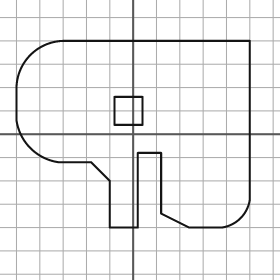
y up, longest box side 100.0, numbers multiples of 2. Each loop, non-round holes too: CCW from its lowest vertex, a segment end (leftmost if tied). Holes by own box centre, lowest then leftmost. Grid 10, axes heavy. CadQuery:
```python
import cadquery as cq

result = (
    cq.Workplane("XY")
    .moveTo(-10.0, -40.0)
    .lineTo(2.0, -40.0)
    .lineTo(2.0, -8.0)
    .lineTo(12.0, -8.0)
    .lineTo(12.0, -34.0)
    .lineTo(24.0, -40.0)
    .lineTo(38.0, -40.0)
    .threePointArc((46.0, -36.0), (50.0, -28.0))
    .lineTo(50.0, 40.0)
    .lineTo(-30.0, 40.0)
    .threePointArc((-44.0, 34.0), (-50.0, 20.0))
    .lineTo(-50.0, 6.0)
    .threePointArc((-44.0, -6.0), (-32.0, -12.0))
    .lineTo(-18.0, -12.0)
    .lineTo(-10.0, -20.0)
    .close()
    .moveTo(-8.0, 4.0)
    .lineTo(4.0, 4.0)
    .lineTo(4.0, 16.0)
    .lineTo(-8.0, 16.0)
    .close()
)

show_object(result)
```